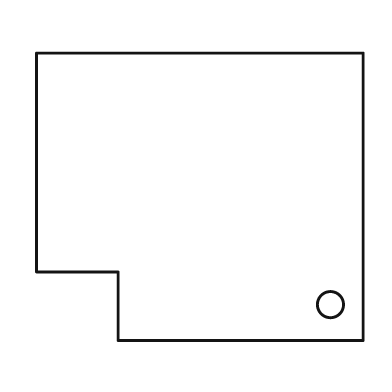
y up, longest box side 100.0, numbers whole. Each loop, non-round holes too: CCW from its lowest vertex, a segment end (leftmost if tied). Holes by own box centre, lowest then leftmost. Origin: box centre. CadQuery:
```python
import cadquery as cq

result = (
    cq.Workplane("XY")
    .moveTo(-25.0, -44.0)
    .lineTo(50.0, -44.0)
    .lineTo(50.0, 44.0)
    .lineTo(-50.0, 44.0)
    .lineTo(-50.0, -23.0)
    .lineTo(-25.0, -23.0)
    .close()
    .moveTo(40.0, -33.0)
    .circle(4.0)
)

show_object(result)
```